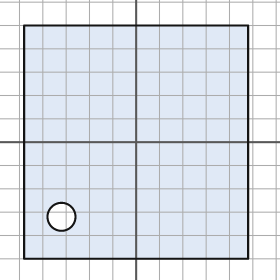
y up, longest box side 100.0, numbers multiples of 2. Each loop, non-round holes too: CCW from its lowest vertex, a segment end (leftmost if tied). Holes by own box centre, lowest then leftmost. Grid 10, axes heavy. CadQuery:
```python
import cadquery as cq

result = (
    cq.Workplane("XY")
    .moveTo(-48.0, -50.0)
    .lineTo(48.0, -50.0)
    .lineTo(48.0, 50.0)
    .lineTo(-48.0, 50.0)
    .close()
    .moveTo(-32.0, -32.0)
    .circle(6.0)
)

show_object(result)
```